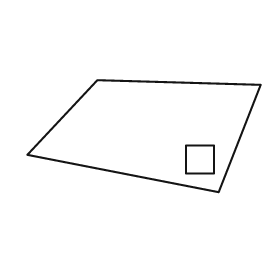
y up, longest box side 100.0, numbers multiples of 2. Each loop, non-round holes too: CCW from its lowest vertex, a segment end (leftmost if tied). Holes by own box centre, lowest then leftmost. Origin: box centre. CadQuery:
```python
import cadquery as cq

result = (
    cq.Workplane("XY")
    .moveTo(32.0, -24.0)
    .lineTo(50.0, 22.0)
    .lineTo(-20.0, 24.0)
    .lineTo(-50.0, -8.0)
    .close()
    .moveTo(18.0, -16.0)
    .lineTo(30.0, -16.0)
    .lineTo(30.0, -4.0)
    .lineTo(18.0, -4.0)
    .close()
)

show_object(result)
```